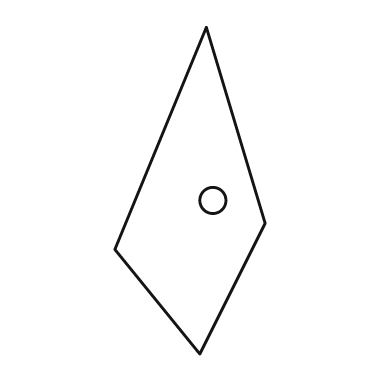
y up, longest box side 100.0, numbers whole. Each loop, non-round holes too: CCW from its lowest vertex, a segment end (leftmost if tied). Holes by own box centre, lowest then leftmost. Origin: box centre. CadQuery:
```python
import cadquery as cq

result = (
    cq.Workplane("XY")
    .moveTo(3.0, -50.0)
    .lineTo(23.0, -10.0)
    .lineTo(5.0, 50.0)
    .lineTo(-23.0, -18.0)
    .close()
    .moveTo(7.0, -3.0)
    .circle(4.0)
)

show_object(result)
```